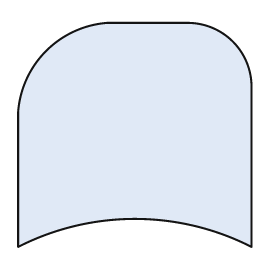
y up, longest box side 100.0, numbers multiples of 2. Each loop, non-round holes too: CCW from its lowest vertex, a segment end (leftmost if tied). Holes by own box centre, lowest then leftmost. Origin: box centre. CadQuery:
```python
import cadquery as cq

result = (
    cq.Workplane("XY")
    .moveTo(-50.0, -48.0)
    .threePointArc((0.0, -36.0), (50.0, -48.0))
    .lineTo(50.0, 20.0)
    .threePointArc((42.0, 40.0), (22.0, 48.0))
    .lineTo(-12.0, 48.0)
    .threePointArc((-38.0, 36.0), (-50.0, 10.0))
    .close()
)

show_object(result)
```